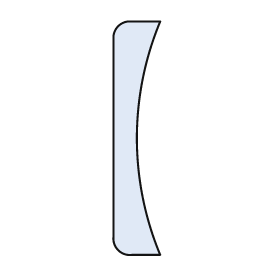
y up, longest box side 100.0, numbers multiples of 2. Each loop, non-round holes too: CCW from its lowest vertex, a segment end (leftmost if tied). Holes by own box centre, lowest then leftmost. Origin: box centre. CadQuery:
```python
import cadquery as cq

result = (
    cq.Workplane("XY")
    .moveTo(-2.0, -50.0)
    .lineTo(10.0, -50.0)
    .threePointArc((0.0, 0.0), (10.0, 50.0))
    .lineTo(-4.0, 50.0)
    .threePointArc((-8.0, 48.0), (-10.0, 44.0))
    .lineTo(-10.0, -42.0)
    .threePointArc((-8.0, -48.0), (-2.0, -50.0))
    .close()
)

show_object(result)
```